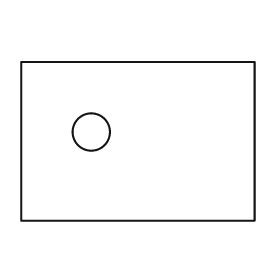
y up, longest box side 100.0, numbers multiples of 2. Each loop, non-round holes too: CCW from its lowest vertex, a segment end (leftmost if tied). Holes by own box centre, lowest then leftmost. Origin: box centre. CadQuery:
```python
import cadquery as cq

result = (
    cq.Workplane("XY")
    .moveTo(-50.0, -34.0)
    .lineTo(50.0, -34.0)
    .lineTo(50.0, 34.0)
    .lineTo(-50.0, 34.0)
    .close()
    .moveTo(-20.0, 4.0)
    .circle(8.0)
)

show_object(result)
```